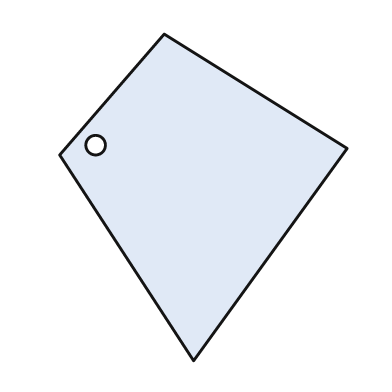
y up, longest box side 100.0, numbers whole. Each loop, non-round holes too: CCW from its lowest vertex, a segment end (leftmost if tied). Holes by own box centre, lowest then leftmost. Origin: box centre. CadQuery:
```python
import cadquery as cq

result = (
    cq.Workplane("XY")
    .moveTo(-3.0, -50.0)
    .lineTo(44.0, 15.0)
    .lineTo(-12.0, 50.0)
    .lineTo(-44.0, 13.0)
    .close()
    .moveTo(-33.0, 16.0)
    .circle(3.0)
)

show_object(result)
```